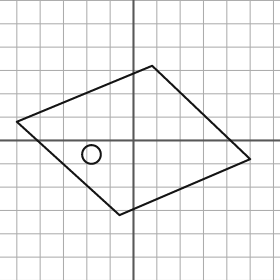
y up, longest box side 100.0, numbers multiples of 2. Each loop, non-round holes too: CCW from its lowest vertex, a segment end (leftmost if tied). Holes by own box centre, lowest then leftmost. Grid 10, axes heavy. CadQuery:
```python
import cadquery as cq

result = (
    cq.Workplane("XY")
    .moveTo(-6.0, -32.0)
    .lineTo(50.0, -8.0)
    .lineTo(8.0, 32.0)
    .lineTo(-50.0, 8.0)
    .close()
    .moveTo(-18.0, -6.0)
    .circle(4.0)
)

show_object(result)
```